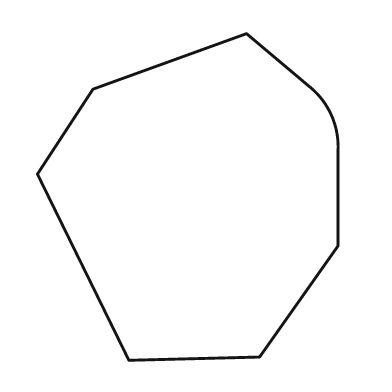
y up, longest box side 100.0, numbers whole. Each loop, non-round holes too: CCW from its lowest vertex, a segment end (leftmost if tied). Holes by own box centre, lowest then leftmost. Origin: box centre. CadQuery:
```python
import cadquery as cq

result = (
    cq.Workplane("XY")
    .moveTo(-18.0, -50.0)
    .lineTo(22.0, -49.0)
    .lineTo(46.0, -15.0)
    .lineTo(46.0, 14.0)
    .threePointArc((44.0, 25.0), (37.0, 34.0))
    .lineTo(18.0, 50.0)
    .lineTo(-29.0, 33.0)
    .lineTo(-46.0, 7.0)
    .close()
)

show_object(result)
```